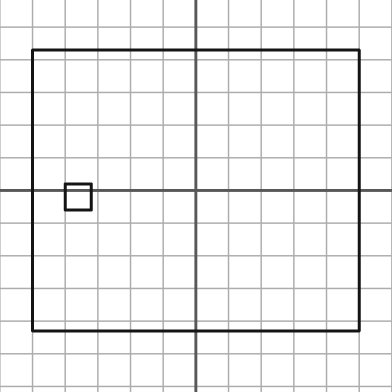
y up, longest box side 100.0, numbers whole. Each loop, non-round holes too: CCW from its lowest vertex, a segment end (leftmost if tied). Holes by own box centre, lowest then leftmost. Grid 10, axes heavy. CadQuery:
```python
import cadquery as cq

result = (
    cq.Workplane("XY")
    .moveTo(-50.0, -43.0)
    .lineTo(50.0, -43.0)
    .lineTo(50.0, 43.0)
    .lineTo(-50.0, 43.0)
    .close()
    .moveTo(-40.0, -6.0)
    .lineTo(-32.0, -6.0)
    .lineTo(-32.0, 2.0)
    .lineTo(-40.0, 2.0)
    .close()
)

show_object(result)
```